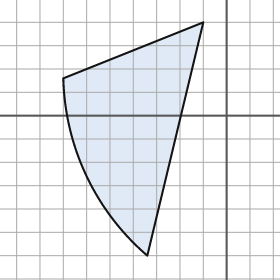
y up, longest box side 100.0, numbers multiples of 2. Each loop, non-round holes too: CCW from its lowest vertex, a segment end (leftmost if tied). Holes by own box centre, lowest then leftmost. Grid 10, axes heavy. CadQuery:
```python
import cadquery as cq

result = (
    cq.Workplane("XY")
    .moveTo(-34.0, -60.0)
    .lineTo(-10.0, 40.0)
    .lineTo(-70.0, 16.0)
    .threePointArc((-60.0, -26.0), (-34.0, -60.0))
    .close()
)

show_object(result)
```